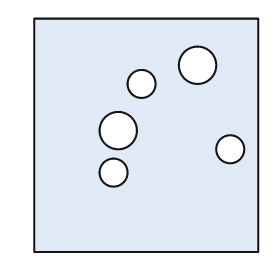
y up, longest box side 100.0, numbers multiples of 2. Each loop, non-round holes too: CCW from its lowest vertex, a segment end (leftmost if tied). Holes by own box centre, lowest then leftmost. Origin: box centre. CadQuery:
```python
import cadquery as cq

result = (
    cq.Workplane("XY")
    .moveTo(-48.0, -50.0)
    .lineTo(48.0, -50.0)
    .lineTo(48.0, 50.0)
    .lineTo(-48.0, 50.0)
    .close()
    .moveTo(-14.0, -16.0)
    .circle(6.0)
    .moveTo(36.0, -6.0)
    .circle(6.0)
    .moveTo(-12.0, 2.0)
    .circle(8.0)
    .moveTo(-2.0, 22.0)
    .circle(6.0)
    .moveTo(22.0, 30.0)
    .circle(8.0)
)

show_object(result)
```